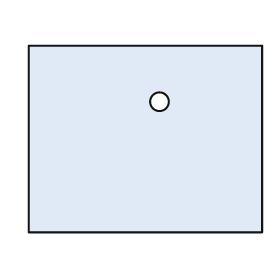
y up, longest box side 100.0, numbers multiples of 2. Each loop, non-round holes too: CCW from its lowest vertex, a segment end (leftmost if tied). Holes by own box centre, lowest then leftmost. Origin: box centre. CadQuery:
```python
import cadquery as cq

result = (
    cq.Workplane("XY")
    .moveTo(-50.0, -40.0)
    .lineTo(50.0, -40.0)
    .lineTo(50.0, 40.0)
    .lineTo(-50.0, 40.0)
    .close()
    .moveTo(6.0, 16.0)
    .circle(4.0)
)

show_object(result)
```